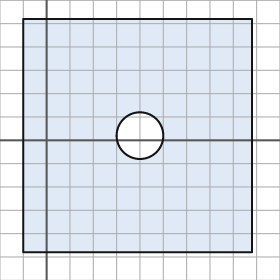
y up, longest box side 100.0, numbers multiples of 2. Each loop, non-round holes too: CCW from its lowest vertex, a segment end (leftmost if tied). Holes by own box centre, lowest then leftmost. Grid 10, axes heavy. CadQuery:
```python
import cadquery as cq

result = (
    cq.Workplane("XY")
    .moveTo(-10.0, -48.0)
    .lineTo(88.0, -48.0)
    .lineTo(88.0, 52.0)
    .lineTo(-10.0, 52.0)
    .close()
    .moveTo(40.0, 2.0)
    .circle(10.0)
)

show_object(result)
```